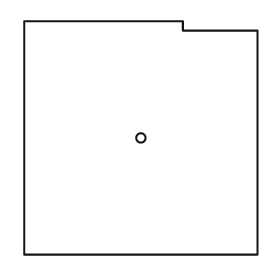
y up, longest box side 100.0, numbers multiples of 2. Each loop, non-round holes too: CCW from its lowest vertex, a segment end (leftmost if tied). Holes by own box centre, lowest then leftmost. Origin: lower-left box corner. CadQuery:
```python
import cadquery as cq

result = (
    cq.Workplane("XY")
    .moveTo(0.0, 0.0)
    .lineTo(100.0, 0.0)
    .lineTo(100.0, 96.0)
    .lineTo(68.0, 96.0)
    .lineTo(68.0, 100.0)
    .lineTo(0.0, 100.0)
    .close()
    .moveTo(50.0, 50.0)
    .circle(2.0)
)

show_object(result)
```